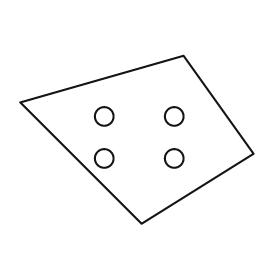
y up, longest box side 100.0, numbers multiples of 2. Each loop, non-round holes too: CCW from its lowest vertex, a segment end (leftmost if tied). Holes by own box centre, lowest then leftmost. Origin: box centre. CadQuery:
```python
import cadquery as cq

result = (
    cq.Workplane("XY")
    .moveTo(2.0, -36.0)
    .lineTo(50.0, -6.0)
    .lineTo(20.0, 36.0)
    .lineTo(-50.0, 16.0)
    .close()
    .moveTo(-14.0, -8.0)
    .circle(4.0)
    .moveTo(16.0, -8.0)
    .circle(4.0)
    .moveTo(-14.0, 10.0)
    .circle(4.0)
    .moveTo(16.0, 10.0)
    .circle(4.0)
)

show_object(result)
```